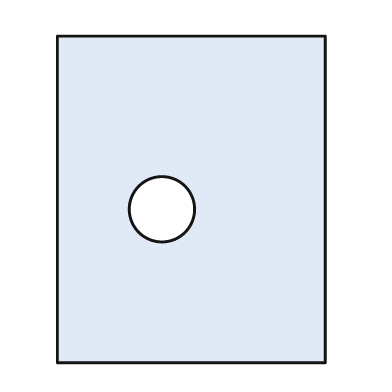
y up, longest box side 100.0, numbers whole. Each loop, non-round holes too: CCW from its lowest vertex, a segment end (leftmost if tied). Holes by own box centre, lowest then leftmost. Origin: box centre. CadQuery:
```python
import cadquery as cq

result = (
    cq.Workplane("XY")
    .moveTo(-41.0, -50.0)
    .lineTo(41.0, -50.0)
    .lineTo(41.0, 50.0)
    .lineTo(-41.0, 50.0)
    .close()
    .moveTo(-9.0, -3.0)
    .circle(10.0)
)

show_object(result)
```